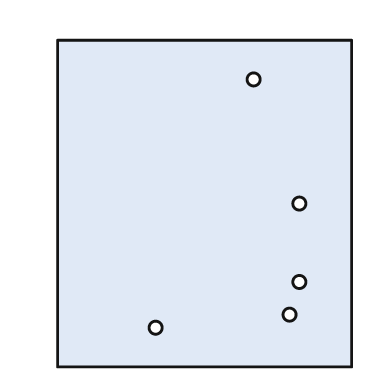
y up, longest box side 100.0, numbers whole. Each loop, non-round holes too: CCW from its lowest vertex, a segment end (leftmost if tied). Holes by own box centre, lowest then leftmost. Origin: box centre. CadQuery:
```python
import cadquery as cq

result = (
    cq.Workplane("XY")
    .moveTo(-45.0, -50.0)
    .lineTo(45.0, -50.0)
    .lineTo(45.0, 50.0)
    .lineTo(-45.0, 50.0)
    .close()
    .moveTo(-15.0, -38.0)
    .circle(2.0)
    .moveTo(26.0, -34.0)
    .circle(2.0)
    .moveTo(29.0, -24.0)
    .circle(2.0)
    .moveTo(29.0, 0.0)
    .circle(2.0)
    .moveTo(15.0, 38.0)
    .circle(2.0)
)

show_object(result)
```